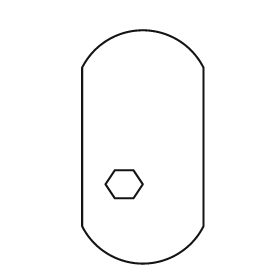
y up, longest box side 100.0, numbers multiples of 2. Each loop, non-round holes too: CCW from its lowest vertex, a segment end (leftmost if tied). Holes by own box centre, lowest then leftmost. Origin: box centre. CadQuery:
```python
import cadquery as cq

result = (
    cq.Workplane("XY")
    .moveTo(-26.0, -34.0)
    .threePointArc((0.0, -50.0), (26.0, -34.0))
    .lineTo(26.0, 34.0)
    .threePointArc((0.0, 50.0), (-26.0, 34.0))
    .close()
    .moveTo(-12.0, -22.0)
    .lineTo(-4.0, -22.0)
    .lineTo(0.0, -16.0)
    .lineTo(-4.0, -10.0)
    .lineTo(-12.0, -10.0)
    .lineTo(-16.0, -16.0)
    .close()
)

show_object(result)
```